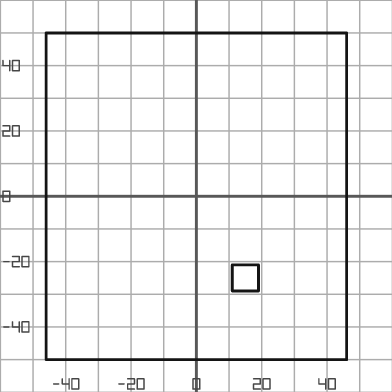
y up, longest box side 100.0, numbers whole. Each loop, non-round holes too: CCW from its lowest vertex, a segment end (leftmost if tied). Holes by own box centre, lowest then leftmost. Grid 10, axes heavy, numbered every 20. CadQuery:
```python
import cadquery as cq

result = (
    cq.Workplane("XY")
    .moveTo(-46.0, -50.0)
    .lineTo(46.0, -50.0)
    .lineTo(46.0, 50.0)
    .lineTo(-46.0, 50.0)
    .close()
    .moveTo(11.0, -29.0)
    .lineTo(19.0, -29.0)
    .lineTo(19.0, -21.0)
    .lineTo(11.0, -21.0)
    .close()
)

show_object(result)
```